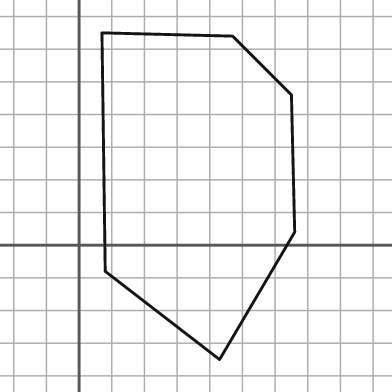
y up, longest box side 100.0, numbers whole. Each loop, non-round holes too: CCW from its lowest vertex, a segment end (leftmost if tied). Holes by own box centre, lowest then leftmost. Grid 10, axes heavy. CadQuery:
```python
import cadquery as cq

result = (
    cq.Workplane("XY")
    .moveTo(43.0, -35.0)
    .lineTo(66.0, 4.0)
    .lineTo(65.0, 46.0)
    .lineTo(47.0, 64.0)
    .lineTo(7.0, 65.0)
    .lineTo(8.0, -8.0)
    .close()
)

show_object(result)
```